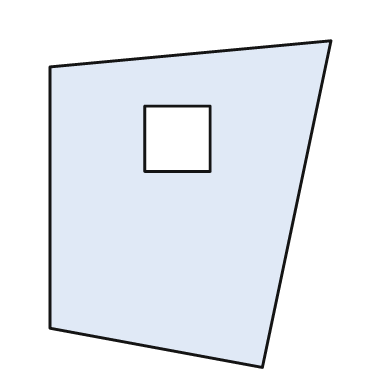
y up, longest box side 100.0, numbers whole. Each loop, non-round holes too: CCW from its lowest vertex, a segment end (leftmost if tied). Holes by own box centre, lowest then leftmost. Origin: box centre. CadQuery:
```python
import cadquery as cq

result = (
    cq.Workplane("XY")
    .moveTo(22.0, -50.0)
    .lineTo(43.0, 50.0)
    .lineTo(-43.0, 42.0)
    .lineTo(-43.0, -38.0)
    .close()
    .moveTo(-14.0, 10.0)
    .lineTo(6.0, 10.0)
    .lineTo(6.0, 30.0)
    .lineTo(-14.0, 30.0)
    .close()
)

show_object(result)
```